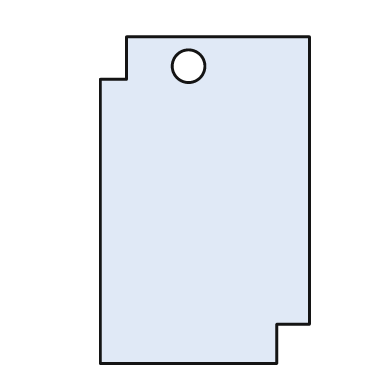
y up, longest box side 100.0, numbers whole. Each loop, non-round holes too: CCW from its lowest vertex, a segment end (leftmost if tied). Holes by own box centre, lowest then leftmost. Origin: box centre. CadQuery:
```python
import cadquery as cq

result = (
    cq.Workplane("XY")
    .moveTo(-32.0, -50.0)
    .lineTo(22.0, -50.0)
    .lineTo(22.0, -38.0)
    .lineTo(32.0, -38.0)
    .lineTo(32.0, 50.0)
    .lineTo(-24.0, 50.0)
    .lineTo(-24.0, 37.0)
    .lineTo(-32.0, 37.0)
    .close()
    .moveTo(-5.0, 41.0)
    .circle(5.0)
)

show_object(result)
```